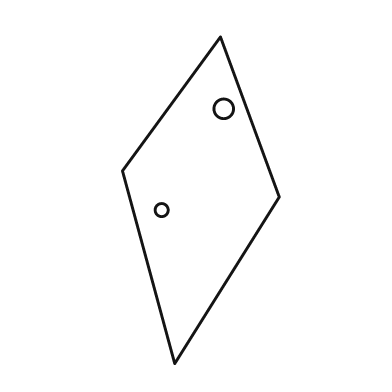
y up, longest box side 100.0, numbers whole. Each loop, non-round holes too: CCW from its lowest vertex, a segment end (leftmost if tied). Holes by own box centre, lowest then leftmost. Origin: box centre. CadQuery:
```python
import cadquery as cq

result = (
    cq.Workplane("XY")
    .moveTo(-8.0, -50.0)
    .lineTo(24.0, 1.0)
    .lineTo(6.0, 50.0)
    .lineTo(-24.0, 9.0)
    .close()
    .moveTo(-12.0, -3.0)
    .circle(2.0)
    .moveTo(7.0, 28.0)
    .circle(3.0)
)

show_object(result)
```